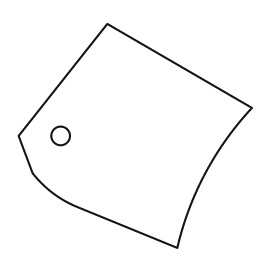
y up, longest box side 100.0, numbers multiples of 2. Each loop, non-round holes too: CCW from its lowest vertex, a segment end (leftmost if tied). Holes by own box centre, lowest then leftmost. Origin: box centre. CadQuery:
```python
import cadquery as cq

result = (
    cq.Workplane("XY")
    .moveTo(18.0, -48.0)
    .threePointArc((30.0, -16.0), (50.0, 12.0))
    .lineTo(-12.0, 48.0)
    .lineTo(-50.0, 0.0)
    .lineTo(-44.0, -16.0)
    .threePointArc((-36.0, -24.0), (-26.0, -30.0))
    .close()
    .moveTo(-32.0, 0.0)
    .circle(4.0)
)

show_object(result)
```